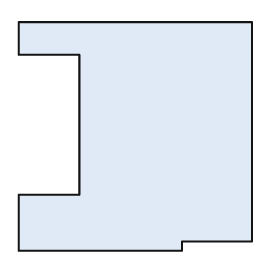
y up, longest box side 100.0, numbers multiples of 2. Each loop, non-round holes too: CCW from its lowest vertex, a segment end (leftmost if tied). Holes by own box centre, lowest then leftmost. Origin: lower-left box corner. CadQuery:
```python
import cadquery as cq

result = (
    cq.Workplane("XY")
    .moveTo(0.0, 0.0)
    .lineTo(70.0, 0.0)
    .lineTo(70.0, 4.0)
    .lineTo(100.0, 4.0)
    .lineTo(100.0, 98.0)
    .lineTo(0.0, 98.0)
    .lineTo(0.0, 84.0)
    .lineTo(26.0, 84.0)
    .lineTo(26.0, 24.0)
    .lineTo(0.0, 24.0)
    .close()
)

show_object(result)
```